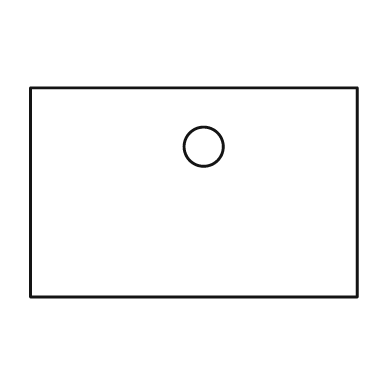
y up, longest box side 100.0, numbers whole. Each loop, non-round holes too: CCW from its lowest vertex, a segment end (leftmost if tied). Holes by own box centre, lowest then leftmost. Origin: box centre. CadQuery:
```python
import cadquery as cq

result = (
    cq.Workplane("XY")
    .moveTo(-50.0, -32.0)
    .lineTo(50.0, -32.0)
    .lineTo(50.0, 32.0)
    .lineTo(-50.0, 32.0)
    .close()
    .moveTo(3.0, 14.0)
    .circle(6.0)
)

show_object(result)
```